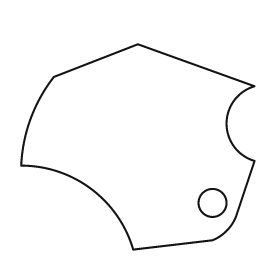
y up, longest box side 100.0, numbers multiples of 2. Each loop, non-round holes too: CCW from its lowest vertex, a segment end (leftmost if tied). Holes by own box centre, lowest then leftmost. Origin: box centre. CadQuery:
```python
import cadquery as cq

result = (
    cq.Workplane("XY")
    .moveTo(-2.0, -44.0)
    .lineTo(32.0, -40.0)
    .threePointArc((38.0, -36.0), (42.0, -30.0))
    .lineTo(50.0, -6.0)
    .threePointArc((38.0, 10.0), (50.0, 26.0))
    .lineTo(0.0, 44.0)
    .lineTo(-36.0, 30.0)
    .threePointArc((-46.0, 12.0), (-50.0, -8.0))
    .threePointArc((-20.0, -18.0), (-2.0, -44.0))
    .close()
    .moveTo(32.0, -24.0)
    .circle(6.0)
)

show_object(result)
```